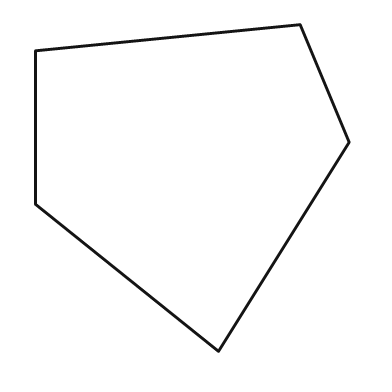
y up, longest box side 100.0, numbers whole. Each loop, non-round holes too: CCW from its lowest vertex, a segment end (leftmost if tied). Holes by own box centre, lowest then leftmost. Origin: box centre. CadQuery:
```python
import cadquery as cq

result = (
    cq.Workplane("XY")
    .moveTo(8.0, -50.0)
    .lineTo(48.0, 14.0)
    .lineTo(33.0, 50.0)
    .lineTo(-48.0, 42.0)
    .lineTo(-48.0, -5.0)
    .close()
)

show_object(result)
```